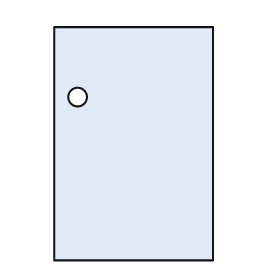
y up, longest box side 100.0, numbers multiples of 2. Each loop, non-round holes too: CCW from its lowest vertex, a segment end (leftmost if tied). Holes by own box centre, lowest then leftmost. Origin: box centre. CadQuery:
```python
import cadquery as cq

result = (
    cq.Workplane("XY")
    .moveTo(-34.0, -50.0)
    .lineTo(34.0, -50.0)
    .lineTo(34.0, 50.0)
    .lineTo(-34.0, 50.0)
    .close()
    .moveTo(-24.0, 20.0)
    .circle(4.0)
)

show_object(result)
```